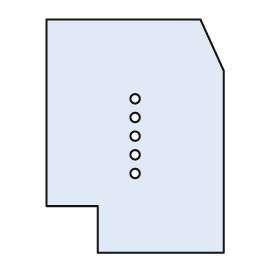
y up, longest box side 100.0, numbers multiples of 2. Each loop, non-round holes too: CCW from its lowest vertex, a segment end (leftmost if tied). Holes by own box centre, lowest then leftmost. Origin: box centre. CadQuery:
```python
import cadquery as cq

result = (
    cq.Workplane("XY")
    .moveTo(-16.0, -50.0)
    .lineTo(38.0, -50.0)
    .lineTo(38.0, 28.0)
    .lineTo(28.0, 50.0)
    .lineTo(-38.0, 50.0)
    .lineTo(-38.0, -30.0)
    .lineTo(-16.0, -30.0)
    .close()
    .moveTo(0.0, -16.0)
    .circle(2.0)
    .moveTo(0.0, -8.0)
    .circle(2.0)
    .moveTo(0.0, 0.0)
    .circle(2.0)
    .moveTo(0.0, 8.0)
    .circle(2.0)
    .moveTo(0.0, 16.0)
    .circle(2.0)
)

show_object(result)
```